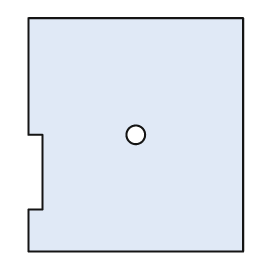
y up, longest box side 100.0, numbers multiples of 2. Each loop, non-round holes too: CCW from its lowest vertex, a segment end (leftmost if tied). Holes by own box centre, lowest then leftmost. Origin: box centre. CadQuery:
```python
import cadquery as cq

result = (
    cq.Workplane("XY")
    .moveTo(-46.0, -50.0)
    .lineTo(46.0, -50.0)
    .lineTo(46.0, 50.0)
    .lineTo(-46.0, 50.0)
    .lineTo(-46.0, 0.0)
    .lineTo(-40.0, 0.0)
    .lineTo(-40.0, -32.0)
    .lineTo(-46.0, -32.0)
    .close()
    .moveTo(0.0, 0.0)
    .circle(4.0)
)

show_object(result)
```